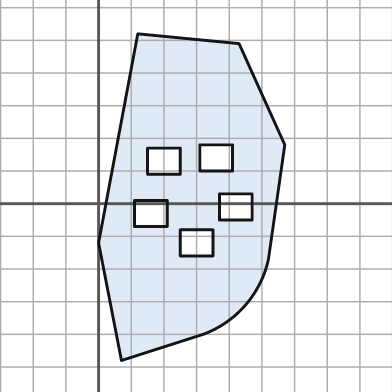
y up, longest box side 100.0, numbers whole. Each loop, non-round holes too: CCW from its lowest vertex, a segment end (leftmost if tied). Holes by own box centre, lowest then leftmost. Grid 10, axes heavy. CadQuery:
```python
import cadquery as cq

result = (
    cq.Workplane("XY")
    .moveTo(7.0, -48.0)
    .lineTo(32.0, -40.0)
    .threePointArc((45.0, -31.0), (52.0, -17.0))
    .lineTo(57.0, 18.0)
    .lineTo(43.0, 49.0)
    .lineTo(12.0, 52.0)
    .lineTo(0.0, -12.0)
    .close()
    .moveTo(25.0, -16.0)
    .lineTo(35.0, -16.0)
    .lineTo(35.0, -8.0)
    .lineTo(25.0, -8.0)
    .close()
    .moveTo(11.0, -7.0)
    .lineTo(21.0, -7.0)
    .lineTo(21.0, 1.0)
    .lineTo(11.0, 1.0)
    .close()
    .moveTo(37.0, -5.0)
    .lineTo(47.0, -5.0)
    .lineTo(47.0, 3.0)
    .lineTo(37.0, 3.0)
    .close()
    .moveTo(15.0, 9.0)
    .lineTo(25.0, 9.0)
    .lineTo(25.0, 17.0)
    .lineTo(15.0, 17.0)
    .close()
    .moveTo(31.0, 10.0)
    .lineTo(41.0, 10.0)
    .lineTo(41.0, 18.0)
    .lineTo(31.0, 18.0)
    .close()
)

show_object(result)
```